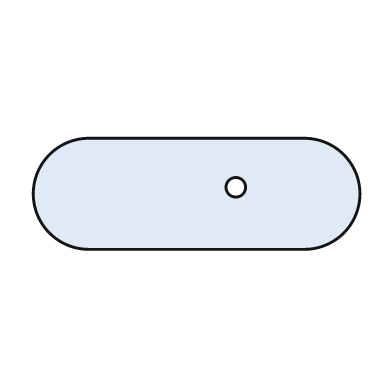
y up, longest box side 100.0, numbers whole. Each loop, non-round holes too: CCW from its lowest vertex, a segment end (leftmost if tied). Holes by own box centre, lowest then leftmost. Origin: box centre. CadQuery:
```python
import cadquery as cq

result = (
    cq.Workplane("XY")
    .moveTo(-33.0, -17.0)
    .lineTo(33.0, -17.0)
    .threePointArc((50.0, 0.0), (33.0, 17.0))
    .lineTo(-33.0, 17.0)
    .threePointArc((-50.0, 0.0), (-33.0, -17.0))
    .close()
    .moveTo(12.0, 2.0)
    .circle(3.0)
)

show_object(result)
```